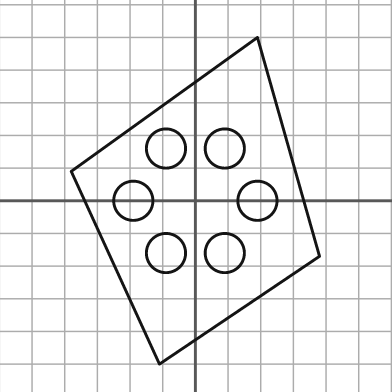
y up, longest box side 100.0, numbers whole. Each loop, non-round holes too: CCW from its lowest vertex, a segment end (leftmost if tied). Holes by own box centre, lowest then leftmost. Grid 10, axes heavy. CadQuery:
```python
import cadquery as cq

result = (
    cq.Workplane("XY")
    .moveTo(-11.0, -50.0)
    .lineTo(38.0, -17.0)
    .lineTo(19.0, 50.0)
    .lineTo(-38.0, 9.0)
    .close()
    .moveTo(-9.0, -16.0)
    .circle(6.0)
    .moveTo(9.0, -16.0)
    .circle(6.0)
    .moveTo(-19.0, 0.0)
    .circle(6.0)
    .moveTo(19.0, 0.0)
    .circle(6.0)
    .moveTo(-9.0, 16.0)
    .circle(6.0)
    .moveTo(9.0, 16.0)
    .circle(6.0)
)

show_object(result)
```